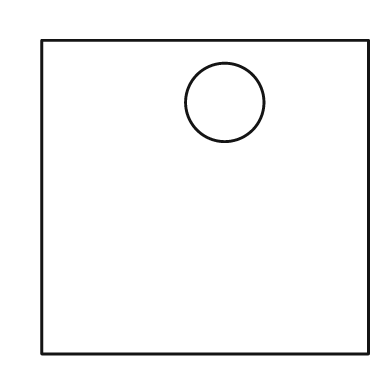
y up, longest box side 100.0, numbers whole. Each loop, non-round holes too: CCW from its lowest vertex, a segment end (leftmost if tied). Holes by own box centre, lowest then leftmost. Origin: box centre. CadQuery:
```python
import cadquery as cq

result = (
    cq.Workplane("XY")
    .moveTo(-50.0, -48.0)
    .lineTo(50.0, -48.0)
    .lineTo(50.0, 48.0)
    .lineTo(-50.0, 48.0)
    .close()
    .moveTo(6.0, 29.0)
    .circle(12.0)
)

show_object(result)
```